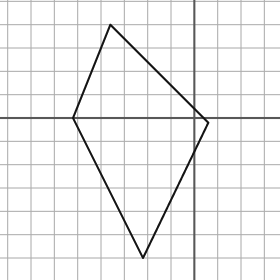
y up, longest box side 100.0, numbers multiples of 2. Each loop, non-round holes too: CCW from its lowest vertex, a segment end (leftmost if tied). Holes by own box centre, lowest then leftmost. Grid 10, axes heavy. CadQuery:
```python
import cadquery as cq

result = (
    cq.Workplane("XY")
    .moveTo(-22.0, -60.0)
    .lineTo(6.0, -2.0)
    .lineTo(-36.0, 40.0)
    .lineTo(-52.0, 0.0)
    .close()
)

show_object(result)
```